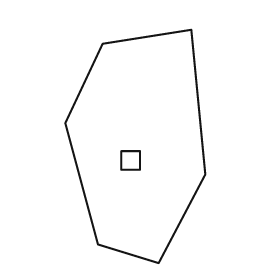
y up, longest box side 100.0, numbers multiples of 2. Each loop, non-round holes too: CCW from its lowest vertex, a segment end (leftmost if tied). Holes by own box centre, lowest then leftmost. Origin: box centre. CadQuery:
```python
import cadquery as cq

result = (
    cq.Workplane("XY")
    .moveTo(10.0, -50.0)
    .lineTo(30.0, -12.0)
    .lineTo(24.0, 50.0)
    .lineTo(-14.0, 44.0)
    .lineTo(-30.0, 10.0)
    .lineTo(-16.0, -42.0)
    .close()
    .moveTo(-6.0, -10.0)
    .lineTo(2.0, -10.0)
    .lineTo(2.0, -2.0)
    .lineTo(-6.0, -2.0)
    .close()
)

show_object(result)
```